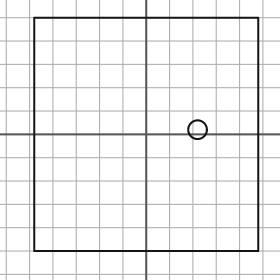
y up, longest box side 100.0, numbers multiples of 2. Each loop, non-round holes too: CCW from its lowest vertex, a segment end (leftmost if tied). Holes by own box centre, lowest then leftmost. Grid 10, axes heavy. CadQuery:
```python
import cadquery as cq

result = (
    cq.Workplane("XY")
    .moveTo(-48.0, -50.0)
    .lineTo(48.0, -50.0)
    .lineTo(48.0, 50.0)
    .lineTo(-48.0, 50.0)
    .close()
    .moveTo(22.0, 2.0)
    .circle(4.0)
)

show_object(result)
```